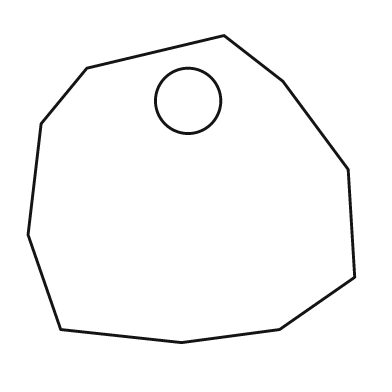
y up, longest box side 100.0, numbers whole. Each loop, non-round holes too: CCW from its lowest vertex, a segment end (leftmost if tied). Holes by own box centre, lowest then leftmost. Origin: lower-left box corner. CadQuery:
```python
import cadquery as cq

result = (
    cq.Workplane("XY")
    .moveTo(47.0, 0.0)
    .lineTo(77.0, 4.0)
    .lineTo(100.0, 20.0)
    .lineTo(98.0, 53.0)
    .lineTo(78.0, 80.0)
    .lineTo(60.0, 94.0)
    .lineTo(18.0, 84.0)
    .lineTo(4.0, 67.0)
    .lineTo(0.0, 33.0)
    .lineTo(10.0, 4.0)
    .close()
    .moveTo(49.0, 74.0)
    .circle(10.0)
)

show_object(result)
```